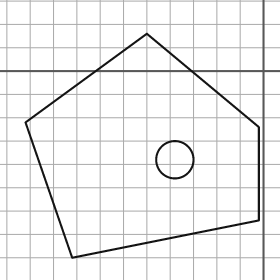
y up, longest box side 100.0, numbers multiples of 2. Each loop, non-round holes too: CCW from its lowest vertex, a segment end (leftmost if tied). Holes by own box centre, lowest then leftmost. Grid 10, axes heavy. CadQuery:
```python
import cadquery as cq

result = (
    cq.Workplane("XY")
    .moveTo(-82.0, -80.0)
    .lineTo(-2.0, -64.0)
    .lineTo(-2.0, -24.0)
    .lineTo(-50.0, 16.0)
    .lineTo(-102.0, -22.0)
    .close()
    .moveTo(-38.0, -38.0)
    .circle(8.0)
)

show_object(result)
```